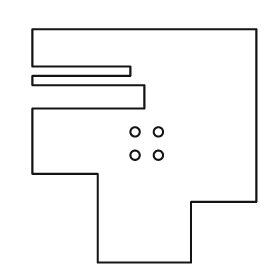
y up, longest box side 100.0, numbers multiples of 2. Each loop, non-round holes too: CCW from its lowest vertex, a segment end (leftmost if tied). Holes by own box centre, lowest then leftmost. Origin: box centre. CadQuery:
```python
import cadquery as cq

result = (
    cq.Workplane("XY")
    .moveTo(-20.0, -50.0)
    .lineTo(20.0, -50.0)
    .lineTo(20.0, -24.0)
    .lineTo(48.0, -24.0)
    .lineTo(48.0, 50.0)
    .lineTo(-48.0, 50.0)
    .lineTo(-48.0, 34.0)
    .lineTo(-6.0, 34.0)
    .lineTo(-6.0, 30.0)
    .lineTo(-48.0, 30.0)
    .lineTo(-48.0, 26.0)
    .lineTo(0.0, 26.0)
    .lineTo(0.0, 16.0)
    .lineTo(-48.0, 16.0)
    .lineTo(-48.0, -12.0)
    .lineTo(-20.0, -12.0)
    .close()
    .moveTo(-4.0, -4.0)
    .circle(2.0)
    .moveTo(6.0, -4.0)
    .circle(2.0)
    .moveTo(-4.0, 6.0)
    .circle(2.0)
    .moveTo(6.0, 6.0)
    .circle(2.0)
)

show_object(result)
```